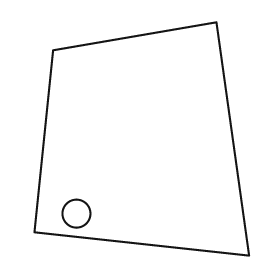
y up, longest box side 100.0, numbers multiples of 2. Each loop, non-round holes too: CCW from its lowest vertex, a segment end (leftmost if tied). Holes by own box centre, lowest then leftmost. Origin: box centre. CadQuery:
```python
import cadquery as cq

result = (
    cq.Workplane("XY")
    .moveTo(46.0, -50.0)
    .lineTo(32.0, 50.0)
    .lineTo(-38.0, 38.0)
    .lineTo(-46.0, -40.0)
    .close()
    .moveTo(-28.0, -32.0)
    .circle(6.0)
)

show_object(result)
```